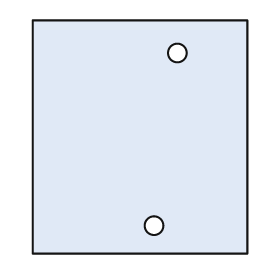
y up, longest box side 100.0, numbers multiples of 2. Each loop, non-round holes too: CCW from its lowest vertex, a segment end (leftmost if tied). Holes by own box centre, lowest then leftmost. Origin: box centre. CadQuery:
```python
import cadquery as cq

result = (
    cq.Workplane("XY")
    .moveTo(-46.0, -50.0)
    .lineTo(46.0, -50.0)
    .lineTo(46.0, 50.0)
    .lineTo(-46.0, 50.0)
    .close()
    .moveTo(6.0, -38.0)
    .circle(4.0)
    .moveTo(16.0, 36.0)
    .circle(4.0)
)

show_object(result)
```